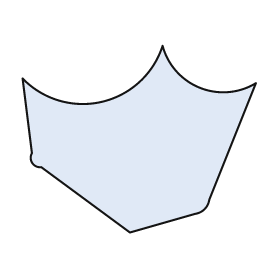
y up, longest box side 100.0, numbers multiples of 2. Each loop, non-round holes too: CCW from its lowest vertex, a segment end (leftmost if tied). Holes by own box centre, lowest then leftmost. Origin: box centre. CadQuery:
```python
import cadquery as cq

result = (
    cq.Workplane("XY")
    .moveTo(-4.0, -40.0)
    .lineTo(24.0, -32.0)
    .threePointArc((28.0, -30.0), (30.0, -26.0))
    .lineTo(50.0, 24.0)
    .threePointArc((26.0, 22.0), (10.0, 40.0))
    .threePointArc((-16.0, 16.0), (-50.0, 26.0))
    .lineTo(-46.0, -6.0)
    .threePointArc((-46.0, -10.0), (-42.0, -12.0))
    .close()
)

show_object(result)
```